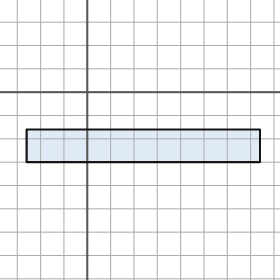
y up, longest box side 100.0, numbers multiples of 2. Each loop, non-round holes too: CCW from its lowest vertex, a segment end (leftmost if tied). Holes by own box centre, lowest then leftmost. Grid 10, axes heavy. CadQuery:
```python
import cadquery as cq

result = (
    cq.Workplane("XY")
    .moveTo(-26.0, -30.0)
    .lineTo(74.0, -30.0)
    .lineTo(74.0, -16.0)
    .lineTo(-26.0, -16.0)
    .close()
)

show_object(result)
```